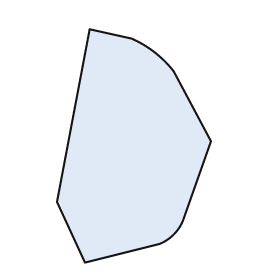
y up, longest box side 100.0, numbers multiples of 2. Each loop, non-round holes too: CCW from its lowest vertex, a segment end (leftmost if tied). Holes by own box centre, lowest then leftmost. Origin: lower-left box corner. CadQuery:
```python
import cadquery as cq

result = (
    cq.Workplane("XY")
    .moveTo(12.0, 0.0)
    .lineTo(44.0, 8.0)
    .threePointArc((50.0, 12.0), (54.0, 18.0))
    .lineTo(66.0, 52.0)
    .lineTo(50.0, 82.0)
    .threePointArc((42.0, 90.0), (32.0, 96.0))
    .lineTo(14.0, 100.0)
    .lineTo(0.0, 26.0)
    .close()
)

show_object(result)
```